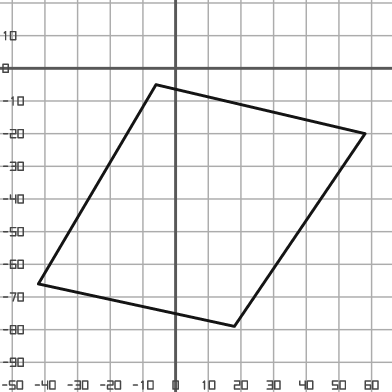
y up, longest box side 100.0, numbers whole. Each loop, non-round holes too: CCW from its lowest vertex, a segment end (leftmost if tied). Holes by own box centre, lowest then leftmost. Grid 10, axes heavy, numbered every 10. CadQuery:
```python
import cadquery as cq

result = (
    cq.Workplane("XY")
    .moveTo(18.0, -79.0)
    .lineTo(58.0, -20.0)
    .lineTo(-6.0, -5.0)
    .lineTo(-42.0, -66.0)
    .close()
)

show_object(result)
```